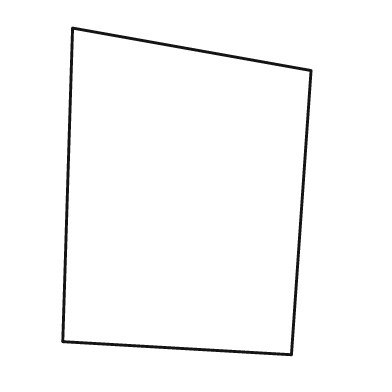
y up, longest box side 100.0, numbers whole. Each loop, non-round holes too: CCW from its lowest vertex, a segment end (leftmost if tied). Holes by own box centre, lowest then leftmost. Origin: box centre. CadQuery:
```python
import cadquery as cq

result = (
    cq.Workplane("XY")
    .moveTo(32.0, -50.0)
    .lineTo(38.0, 37.0)
    .lineTo(-35.0, 50.0)
    .lineTo(-38.0, -46.0)
    .close()
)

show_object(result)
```